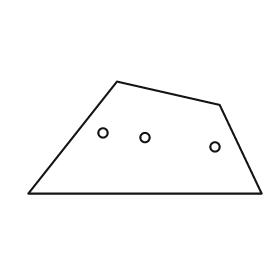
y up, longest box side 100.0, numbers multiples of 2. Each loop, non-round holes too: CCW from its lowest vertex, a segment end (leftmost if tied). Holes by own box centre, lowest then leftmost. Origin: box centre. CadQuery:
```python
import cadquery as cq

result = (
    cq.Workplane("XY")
    .moveTo(-50.0, -24.0)
    .lineTo(50.0, -24.0)
    .lineTo(32.0, 14.0)
    .lineTo(-12.0, 24.0)
    .close()
    .moveTo(30.0, -4.0)
    .circle(2.0)
    .moveTo(0.0, 0.0)
    .circle(2.0)
    .moveTo(-18.0, 2.0)
    .circle(2.0)
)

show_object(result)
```